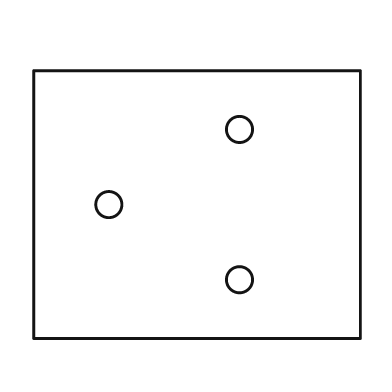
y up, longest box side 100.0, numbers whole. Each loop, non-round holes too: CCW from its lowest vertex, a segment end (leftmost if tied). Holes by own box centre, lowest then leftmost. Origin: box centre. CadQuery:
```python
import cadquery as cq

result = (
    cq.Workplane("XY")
    .moveTo(-50.0, -41.0)
    .lineTo(50.0, -41.0)
    .lineTo(50.0, 41.0)
    .lineTo(-50.0, 41.0)
    .close()
    .moveTo(13.0, -23.0)
    .circle(4.0)
    .moveTo(-27.0, 0.0)
    .circle(4.0)
    .moveTo(13.0, 23.0)
    .circle(4.0)
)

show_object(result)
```